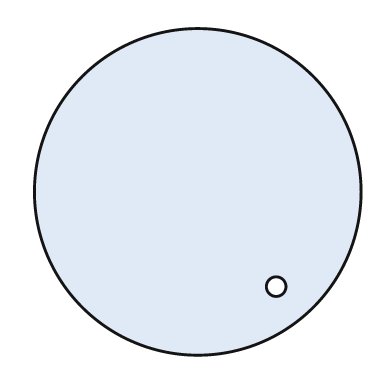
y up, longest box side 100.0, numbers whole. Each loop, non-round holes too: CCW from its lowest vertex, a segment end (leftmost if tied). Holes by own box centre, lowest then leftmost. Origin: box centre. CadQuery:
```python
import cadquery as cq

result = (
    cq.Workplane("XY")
    .moveTo(0.0, 0.0)
    .circle(50.0)
    .moveTo(24.0, -29.0)
    .circle(3.0)
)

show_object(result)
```